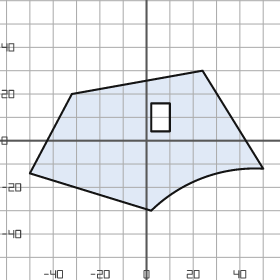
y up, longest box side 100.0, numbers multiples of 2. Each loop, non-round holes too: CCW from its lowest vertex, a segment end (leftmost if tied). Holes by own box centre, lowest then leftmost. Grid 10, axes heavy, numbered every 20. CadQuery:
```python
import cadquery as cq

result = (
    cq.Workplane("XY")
    .moveTo(2.0, -30.0)
    .threePointArc((24.0, -16.0), (50.0, -12.0))
    .lineTo(24.0, 30.0)
    .lineTo(-32.0, 20.0)
    .lineTo(-50.0, -14.0)
    .close()
    .moveTo(2.0, 4.0)
    .lineTo(10.0, 4.0)
    .lineTo(10.0, 16.0)
    .lineTo(2.0, 16.0)
    .close()
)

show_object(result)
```